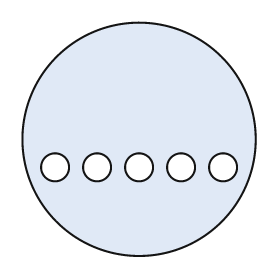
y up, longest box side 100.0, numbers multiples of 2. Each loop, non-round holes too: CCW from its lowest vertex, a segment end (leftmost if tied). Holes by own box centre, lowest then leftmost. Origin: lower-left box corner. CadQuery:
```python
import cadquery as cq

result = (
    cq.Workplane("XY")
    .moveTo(50.0, 50.0)
    .circle(50.0)
    .moveTo(14.0, 38.0)
    .circle(6.0)
    .moveTo(32.0, 38.0)
    .circle(6.0)
    .moveTo(50.0, 38.0)
    .circle(6.0)
    .moveTo(68.0, 38.0)
    .circle(6.0)
    .moveTo(86.0, 38.0)
    .circle(6.0)
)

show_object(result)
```